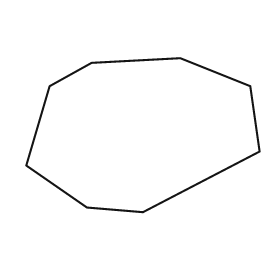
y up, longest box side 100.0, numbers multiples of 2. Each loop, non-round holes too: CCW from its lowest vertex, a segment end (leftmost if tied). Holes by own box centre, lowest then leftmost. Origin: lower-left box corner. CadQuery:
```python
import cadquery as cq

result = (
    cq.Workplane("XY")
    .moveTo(50.0, 0.0)
    .lineTo(100.0, 26.0)
    .lineTo(96.0, 54.0)
    .lineTo(66.0, 66.0)
    .lineTo(28.0, 64.0)
    .lineTo(10.0, 54.0)
    .lineTo(0.0, 20.0)
    .lineTo(26.0, 2.0)
    .close()
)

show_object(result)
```